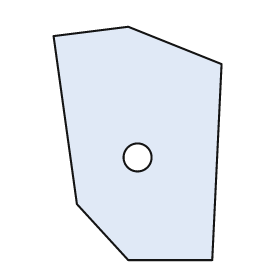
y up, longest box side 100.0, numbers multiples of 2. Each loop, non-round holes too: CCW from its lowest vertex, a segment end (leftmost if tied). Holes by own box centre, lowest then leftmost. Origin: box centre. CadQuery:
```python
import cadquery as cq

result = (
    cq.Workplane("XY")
    .moveTo(-4.0, -50.0)
    .lineTo(32.0, -50.0)
    .lineTo(36.0, 34.0)
    .lineTo(-4.0, 50.0)
    .lineTo(-36.0, 46.0)
    .lineTo(-26.0, -26.0)
    .close()
    .moveTo(0.0, -6.0)
    .circle(6.0)
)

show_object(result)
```